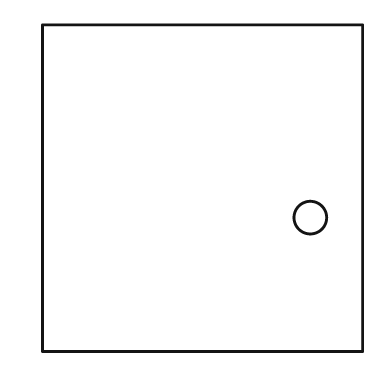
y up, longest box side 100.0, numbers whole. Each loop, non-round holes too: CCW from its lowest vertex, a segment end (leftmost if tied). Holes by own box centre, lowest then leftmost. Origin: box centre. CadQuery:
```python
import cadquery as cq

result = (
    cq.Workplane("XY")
    .moveTo(-49.0, -50.0)
    .lineTo(49.0, -50.0)
    .lineTo(49.0, 50.0)
    .lineTo(-49.0, 50.0)
    .close()
    .moveTo(33.0, -9.0)
    .circle(5.0)
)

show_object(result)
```